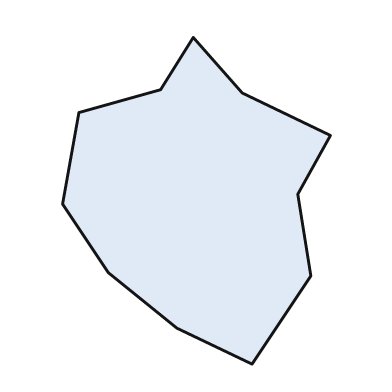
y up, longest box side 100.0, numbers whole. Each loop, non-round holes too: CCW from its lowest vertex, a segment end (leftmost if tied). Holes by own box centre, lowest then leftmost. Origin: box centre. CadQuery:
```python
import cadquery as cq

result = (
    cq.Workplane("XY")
    .moveTo(17.0, -50.0)
    .lineTo(35.0, -23.0)
    .lineTo(31.0, 2.0)
    .lineTo(41.0, 20.0)
    .lineTo(14.0, 33.0)
    .lineTo(-1.0, 50.0)
    .lineTo(-11.0, 34.0)
    .lineTo(-36.0, 27.0)
    .lineTo(-41.0, -1.0)
    .lineTo(-27.0, -22.0)
    .lineTo(-6.0, -39.0)
    .close()
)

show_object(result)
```